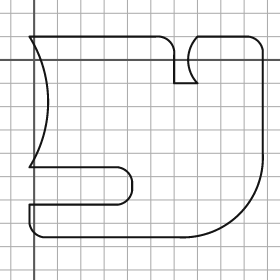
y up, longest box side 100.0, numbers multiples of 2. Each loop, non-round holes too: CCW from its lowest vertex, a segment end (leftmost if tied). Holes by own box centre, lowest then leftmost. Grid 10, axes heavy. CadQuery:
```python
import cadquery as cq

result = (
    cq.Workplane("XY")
    .moveTo(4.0, -76.0)
    .lineTo(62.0, -76.0)
    .threePointArc((88.0, -66.0), (98.0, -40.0))
    .lineTo(98.0, 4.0)
    .threePointArc((96.0, 8.0), (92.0, 10.0))
    .lineTo(70.0, 10.0)
    .threePointArc((66.0, 0.0), (70.0, -10.0))
    .lineTo(60.0, -10.0)
    .lineTo(60.0, 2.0)
    .threePointArc((58.0, 8.0), (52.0, 10.0))
    .lineTo(-2.0, 10.0)
    .threePointArc((6.0, -18.0), (-2.0, -46.0))
    .lineTo(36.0, -46.0)
    .threePointArc((40.0, -48.0), (42.0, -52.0))
    .lineTo(42.0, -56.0)
    .threePointArc((40.0, -60.0), (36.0, -62.0))
    .lineTo(-2.0, -62.0)
    .lineTo(-2.0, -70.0)
    .threePointArc((0.0, -74.0), (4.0, -76.0))
    .close()
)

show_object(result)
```